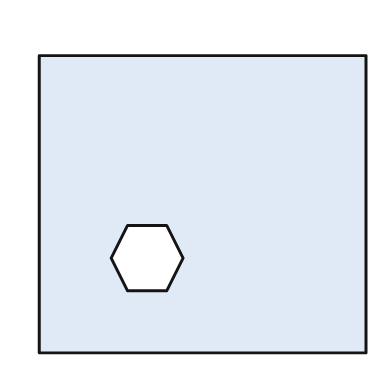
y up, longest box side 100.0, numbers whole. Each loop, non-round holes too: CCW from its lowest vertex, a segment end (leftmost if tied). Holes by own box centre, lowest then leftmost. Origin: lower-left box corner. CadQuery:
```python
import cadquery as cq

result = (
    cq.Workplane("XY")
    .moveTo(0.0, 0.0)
    .lineTo(100.0, 0.0)
    .lineTo(100.0, 91.0)
    .lineTo(0.0, 91.0)
    .close()
    .moveTo(27.0, 19.0)
    .lineTo(39.0, 19.0)
    .lineTo(44.0, 29.0)
    .lineTo(39.0, 39.0)
    .lineTo(27.0, 39.0)
    .lineTo(22.0, 29.0)
    .close()
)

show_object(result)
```